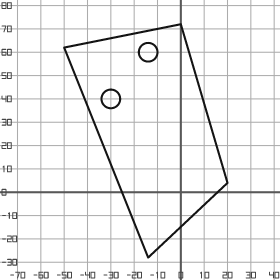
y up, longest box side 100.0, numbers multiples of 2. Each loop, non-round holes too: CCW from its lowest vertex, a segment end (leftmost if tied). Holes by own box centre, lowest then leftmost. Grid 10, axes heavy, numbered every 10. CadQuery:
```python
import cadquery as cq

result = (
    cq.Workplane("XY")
    .moveTo(-14.0, -28.0)
    .lineTo(20.0, 4.0)
    .lineTo(0.0, 72.0)
    .lineTo(-50.0, 62.0)
    .close()
    .moveTo(-30.0, 40.0)
    .circle(4.0)
    .moveTo(-14.0, 60.0)
    .circle(4.0)
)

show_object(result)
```